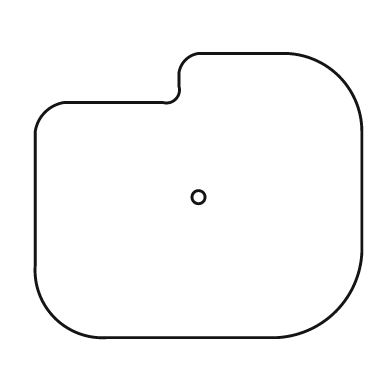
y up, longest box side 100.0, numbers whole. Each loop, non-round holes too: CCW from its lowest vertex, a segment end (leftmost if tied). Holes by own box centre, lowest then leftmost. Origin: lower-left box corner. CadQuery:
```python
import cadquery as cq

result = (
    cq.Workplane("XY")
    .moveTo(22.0, 0.0)
    .lineTo(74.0, 0.0)
    .threePointArc((92.0, 8.0), (100.0, 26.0))
    .lineTo(100.0, 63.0)
    .threePointArc((93.0, 80.0), (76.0, 87.0))
    .lineTo(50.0, 87.0)
    .threePointArc((46.0, 85.0), (44.0, 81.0))
    .lineTo(44.0, 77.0)
    .threePointArc((43.0, 73.0), (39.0, 72.0))
    .lineTo(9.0, 72.0)
    .threePointArc((3.0, 69.0), (0.0, 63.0))
    .lineTo(0.0, 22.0)
    .threePointArc((6.0, 6.0), (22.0, 0.0))
    .close()
    .moveTo(50.0, 43.0)
    .circle(2.0)
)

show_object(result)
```